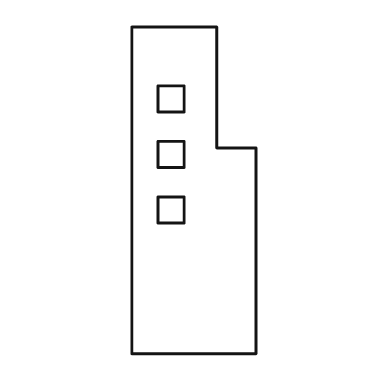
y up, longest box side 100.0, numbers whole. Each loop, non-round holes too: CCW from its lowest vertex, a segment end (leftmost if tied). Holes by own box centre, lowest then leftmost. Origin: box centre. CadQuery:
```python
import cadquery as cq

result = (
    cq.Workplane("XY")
    .moveTo(-19.0, -50.0)
    .lineTo(19.0, -50.0)
    .lineTo(19.0, 13.0)
    .lineTo(7.0, 13.0)
    .lineTo(7.0, 50.0)
    .lineTo(-19.0, 50.0)
    .close()
    .moveTo(-11.0, -10.0)
    .lineTo(-3.0, -10.0)
    .lineTo(-3.0, -2.0)
    .lineTo(-11.0, -2.0)
    .close()
    .moveTo(-11.0, 7.0)
    .lineTo(-3.0, 7.0)
    .lineTo(-3.0, 15.0)
    .lineTo(-11.0, 15.0)
    .close()
    .moveTo(-11.0, 24.0)
    .lineTo(-3.0, 24.0)
    .lineTo(-3.0, 32.0)
    .lineTo(-11.0, 32.0)
    .close()
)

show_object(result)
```